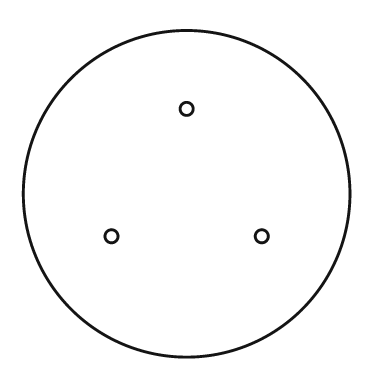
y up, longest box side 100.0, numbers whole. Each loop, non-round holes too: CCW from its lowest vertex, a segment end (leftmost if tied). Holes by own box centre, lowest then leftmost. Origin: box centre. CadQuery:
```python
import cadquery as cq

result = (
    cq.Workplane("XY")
    .moveTo(0.0, 0.0)
    .circle(50.0)
    .moveTo(-23.0, -13.0)
    .circle(2.0)
    .moveTo(23.0, -13.0)
    .circle(2.0)
    .moveTo(0.0, 26.0)
    .circle(2.0)
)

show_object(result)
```